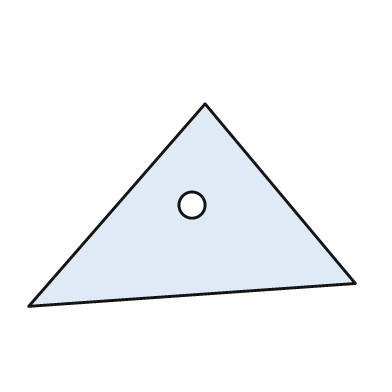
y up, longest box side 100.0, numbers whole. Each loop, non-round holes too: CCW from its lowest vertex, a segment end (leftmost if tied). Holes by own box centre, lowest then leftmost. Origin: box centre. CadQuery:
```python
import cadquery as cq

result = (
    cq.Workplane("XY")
    .moveTo(-50.0, -31.0)
    .lineTo(50.0, -24.0)
    .lineTo(4.0, 31.0)
    .close()
    .moveTo(0.0, 0.0)
    .circle(4.0)
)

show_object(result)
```